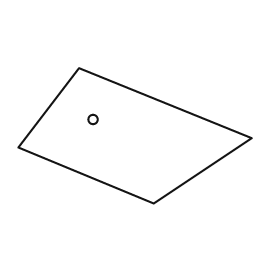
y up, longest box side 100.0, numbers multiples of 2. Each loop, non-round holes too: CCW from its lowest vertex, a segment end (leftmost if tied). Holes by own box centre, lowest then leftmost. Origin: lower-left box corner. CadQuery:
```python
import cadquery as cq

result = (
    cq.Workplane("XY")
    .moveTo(58.0, 0.0)
    .lineTo(100.0, 28.0)
    .lineTo(26.0, 58.0)
    .lineTo(0.0, 24.0)
    .close()
    .moveTo(32.0, 36.0)
    .circle(2.0)
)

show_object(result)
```